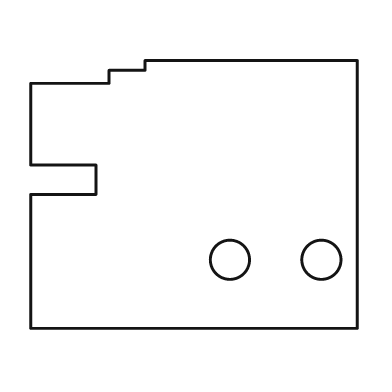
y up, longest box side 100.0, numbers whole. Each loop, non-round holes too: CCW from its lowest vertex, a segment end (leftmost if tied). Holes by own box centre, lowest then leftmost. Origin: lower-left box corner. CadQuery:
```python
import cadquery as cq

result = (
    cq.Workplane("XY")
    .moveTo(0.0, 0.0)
    .lineTo(100.0, 0.0)
    .lineTo(100.0, 82.0)
    .lineTo(35.0, 82.0)
    .lineTo(35.0, 79.0)
    .lineTo(24.0, 79.0)
    .lineTo(24.0, 75.0)
    .lineTo(0.0, 75.0)
    .lineTo(0.0, 50.0)
    .lineTo(20.0, 50.0)
    .lineTo(20.0, 41.0)
    .lineTo(0.0, 41.0)
    .close()
    .moveTo(61.0, 21.0)
    .circle(6.0)
    .moveTo(89.0, 21.0)
    .circle(6.0)
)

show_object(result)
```